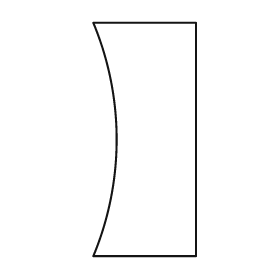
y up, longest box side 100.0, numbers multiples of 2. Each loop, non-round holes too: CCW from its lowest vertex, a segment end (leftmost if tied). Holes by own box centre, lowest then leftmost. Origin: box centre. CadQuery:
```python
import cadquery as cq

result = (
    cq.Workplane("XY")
    .moveTo(-22.0, -50.0)
    .lineTo(22.0, -50.0)
    .lineTo(22.0, 50.0)
    .lineTo(-22.0, 50.0)
    .threePointArc((-12.0, 0.0), (-22.0, -50.0))
    .close()
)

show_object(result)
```